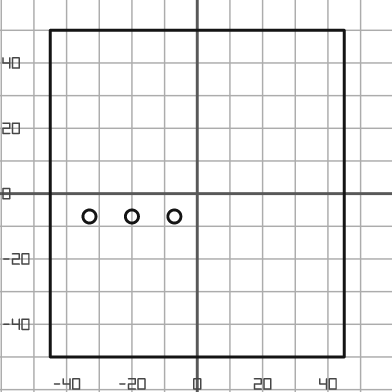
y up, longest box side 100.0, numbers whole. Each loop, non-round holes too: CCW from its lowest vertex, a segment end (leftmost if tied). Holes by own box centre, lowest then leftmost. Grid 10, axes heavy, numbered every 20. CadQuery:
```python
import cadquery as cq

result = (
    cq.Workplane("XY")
    .moveTo(-45.0, -50.0)
    .lineTo(45.0, -50.0)
    .lineTo(45.0, 50.0)
    .lineTo(-45.0, 50.0)
    .close()
    .moveTo(-33.0, -7.0)
    .circle(2.0)
    .moveTo(-20.0, -7.0)
    .circle(2.0)
    .moveTo(-7.0, -7.0)
    .circle(2.0)
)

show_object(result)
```